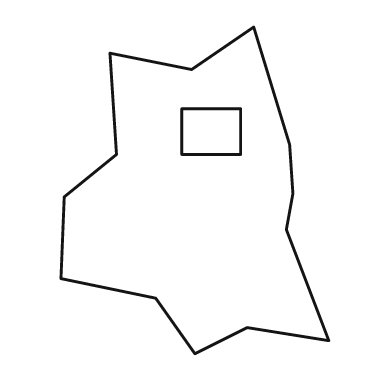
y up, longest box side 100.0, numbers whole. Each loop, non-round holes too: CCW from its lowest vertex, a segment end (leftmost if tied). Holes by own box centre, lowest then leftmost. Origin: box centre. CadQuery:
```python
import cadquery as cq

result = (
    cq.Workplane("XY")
    .moveTo(0.0, -50.0)
    .lineTo(16.0, -42.0)
    .lineTo(41.0, -46.0)
    .lineTo(28.0, -12.0)
    .lineTo(30.0, -1.0)
    .lineTo(29.0, 14.0)
    .lineTo(18.0, 50.0)
    .lineTo(-1.0, 37.0)
    .lineTo(-26.0, 42.0)
    .lineTo(-24.0, 11.0)
    .lineTo(-40.0, -2.0)
    .lineTo(-41.0, -27.0)
    .lineTo(-12.0, -33.0)
    .close()
    .moveTo(-4.0, 11.0)
    .lineTo(14.0, 11.0)
    .lineTo(14.0, 25.0)
    .lineTo(-4.0, 25.0)
    .close()
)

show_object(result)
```